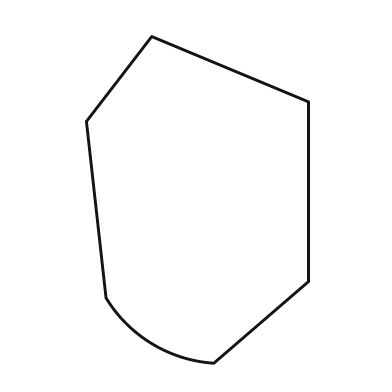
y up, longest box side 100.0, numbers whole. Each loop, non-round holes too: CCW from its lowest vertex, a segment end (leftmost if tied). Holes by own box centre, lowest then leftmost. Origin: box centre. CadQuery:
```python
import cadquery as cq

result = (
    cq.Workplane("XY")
    .moveTo(5.0, -50.0)
    .lineTo(34.0, -25.0)
    .lineTo(34.0, 30.0)
    .lineTo(-14.0, 50.0)
    .lineTo(-34.0, 24.0)
    .lineTo(-28.0, -30.0)
    .threePointArc((-14.0, -44.0), (5.0, -50.0))
    .close()
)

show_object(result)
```